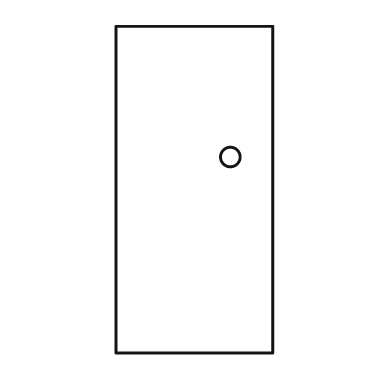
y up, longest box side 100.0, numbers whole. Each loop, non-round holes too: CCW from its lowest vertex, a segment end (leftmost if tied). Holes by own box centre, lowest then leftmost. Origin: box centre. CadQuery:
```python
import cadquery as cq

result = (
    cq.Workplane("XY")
    .moveTo(-24.0, -50.0)
    .lineTo(24.0, -50.0)
    .lineTo(24.0, 50.0)
    .lineTo(-24.0, 50.0)
    .close()
    .moveTo(11.0, 10.0)
    .circle(3.0)
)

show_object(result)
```